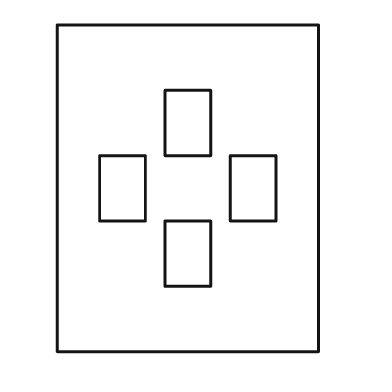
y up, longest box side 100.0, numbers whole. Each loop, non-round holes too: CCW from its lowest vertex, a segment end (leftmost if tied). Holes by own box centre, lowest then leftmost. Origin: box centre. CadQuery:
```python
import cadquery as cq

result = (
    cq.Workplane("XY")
    .moveTo(-40.0, -50.0)
    .lineTo(40.0, -50.0)
    .lineTo(40.0, 50.0)
    .lineTo(-40.0, 50.0)
    .close()
    .moveTo(-7.0, -30.0)
    .lineTo(7.0, -30.0)
    .lineTo(7.0, -10.0)
    .lineTo(-7.0, -10.0)
    .close()
    .moveTo(-27.0, -10.0)
    .lineTo(-13.0, -10.0)
    .lineTo(-13.0, 10.0)
    .lineTo(-27.0, 10.0)
    .close()
    .moveTo(13.0, -10.0)
    .lineTo(27.0, -10.0)
    .lineTo(27.0, 10.0)
    .lineTo(13.0, 10.0)
    .close()
    .moveTo(-7.0, 10.0)
    .lineTo(7.0, 10.0)
    .lineTo(7.0, 30.0)
    .lineTo(-7.0, 30.0)
    .close()
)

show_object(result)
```